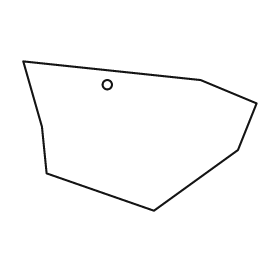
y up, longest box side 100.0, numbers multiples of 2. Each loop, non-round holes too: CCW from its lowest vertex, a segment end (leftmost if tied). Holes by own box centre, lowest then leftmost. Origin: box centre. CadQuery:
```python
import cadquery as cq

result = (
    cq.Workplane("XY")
    .moveTo(6.0, -32.0)
    .lineTo(42.0, -6.0)
    .lineTo(50.0, 14.0)
    .lineTo(26.0, 24.0)
    .lineTo(-50.0, 32.0)
    .lineTo(-42.0, 4.0)
    .lineTo(-40.0, -16.0)
    .close()
    .moveTo(-14.0, 22.0)
    .circle(2.0)
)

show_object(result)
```